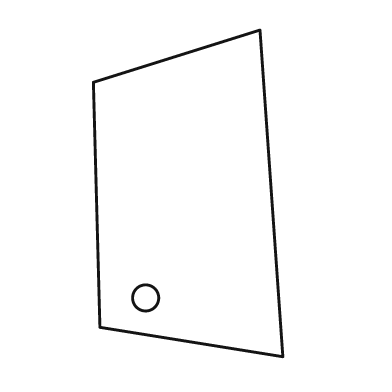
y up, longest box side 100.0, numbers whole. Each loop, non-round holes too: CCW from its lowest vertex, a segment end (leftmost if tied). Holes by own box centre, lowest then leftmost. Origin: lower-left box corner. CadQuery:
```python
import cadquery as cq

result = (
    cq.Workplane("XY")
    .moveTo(58.0, 0.0)
    .lineTo(51.0, 100.0)
    .lineTo(0.0, 84.0)
    .lineTo(2.0, 9.0)
    .close()
    .moveTo(16.0, 18.0)
    .circle(4.0)
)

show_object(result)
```